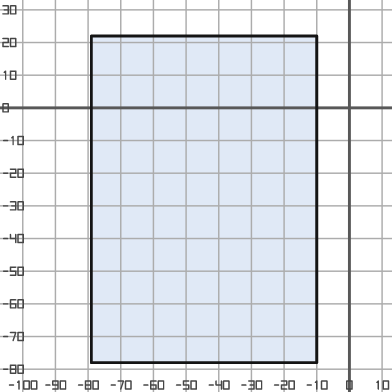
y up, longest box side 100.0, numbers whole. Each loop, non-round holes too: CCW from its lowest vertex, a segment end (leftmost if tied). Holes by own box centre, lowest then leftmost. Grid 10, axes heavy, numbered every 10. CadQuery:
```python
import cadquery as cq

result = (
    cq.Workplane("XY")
    .moveTo(-79.0, -78.0)
    .lineTo(-10.0, -78.0)
    .lineTo(-10.0, 22.0)
    .lineTo(-79.0, 22.0)
    .close()
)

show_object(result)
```